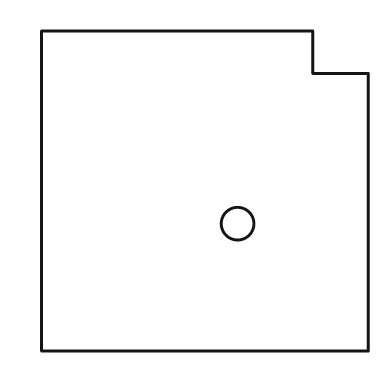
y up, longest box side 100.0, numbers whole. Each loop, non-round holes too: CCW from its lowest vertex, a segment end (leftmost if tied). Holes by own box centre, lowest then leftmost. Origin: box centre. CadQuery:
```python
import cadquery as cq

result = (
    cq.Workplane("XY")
    .moveTo(-50.0, -49.0)
    .lineTo(50.0, -49.0)
    .lineTo(50.0, 36.0)
    .lineTo(33.0, 36.0)
    .lineTo(33.0, 49.0)
    .lineTo(-50.0, 49.0)
    .close()
    .moveTo(10.0, -10.0)
    .circle(5.0)
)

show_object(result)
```